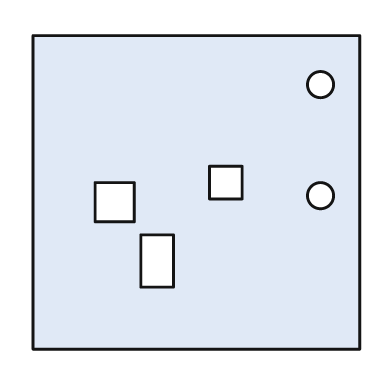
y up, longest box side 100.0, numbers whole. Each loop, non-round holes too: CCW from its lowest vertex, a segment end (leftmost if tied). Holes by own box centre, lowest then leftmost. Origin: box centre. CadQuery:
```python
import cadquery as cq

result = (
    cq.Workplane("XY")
    .moveTo(-50.0, -48.0)
    .lineTo(50.0, -48.0)
    .lineTo(50.0, 48.0)
    .lineTo(-50.0, 48.0)
    .close()
    .moveTo(-17.0, -29.0)
    .lineTo(-7.0, -29.0)
    .lineTo(-7.0, -13.0)
    .lineTo(-17.0, -13.0)
    .close()
    .moveTo(-31.0, -9.0)
    .lineTo(-19.0, -9.0)
    .lineTo(-19.0, 3.0)
    .lineTo(-31.0, 3.0)
    .close()
    .moveTo(38.0, -1.0)
    .circle(4.0)
    .moveTo(4.0, -2.0)
    .lineTo(14.0, -2.0)
    .lineTo(14.0, 8.0)
    .lineTo(4.0, 8.0)
    .close()
    .moveTo(38.0, 33.0)
    .circle(4.0)
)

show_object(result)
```